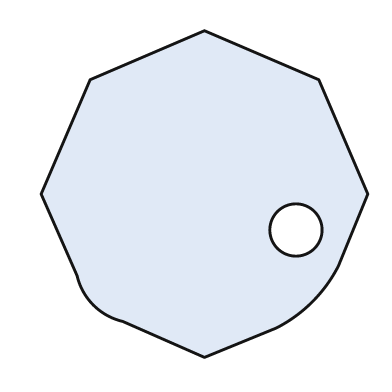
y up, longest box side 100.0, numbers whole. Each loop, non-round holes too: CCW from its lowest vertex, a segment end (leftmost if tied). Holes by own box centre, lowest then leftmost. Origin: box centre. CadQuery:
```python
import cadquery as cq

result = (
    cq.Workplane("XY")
    .moveTo(0.0, -50.0)
    .lineTo(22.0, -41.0)
    .threePointArc((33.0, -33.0), (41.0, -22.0))
    .lineTo(50.0, 0.0)
    .lineTo(35.0, 35.0)
    .lineTo(0.0, 50.0)
    .lineTo(-35.0, 35.0)
    .lineTo(-50.0, 0.0)
    .lineTo(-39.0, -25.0)
    .threePointArc((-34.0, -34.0), (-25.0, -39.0))
    .close()
    .moveTo(28.0, -11.0)
    .circle(8.0)
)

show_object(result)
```